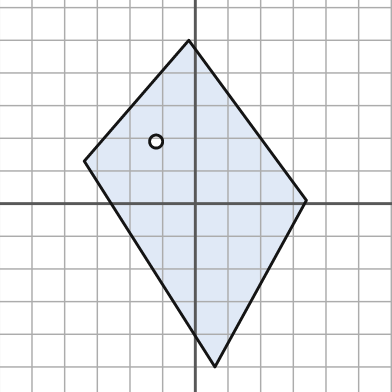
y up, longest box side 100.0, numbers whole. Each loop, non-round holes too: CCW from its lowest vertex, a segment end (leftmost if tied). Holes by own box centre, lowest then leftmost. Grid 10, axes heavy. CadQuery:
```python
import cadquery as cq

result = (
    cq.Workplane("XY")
    .moveTo(6.0, -50.0)
    .lineTo(34.0, 1.0)
    .lineTo(-2.0, 50.0)
    .lineTo(-34.0, 13.0)
    .close()
    .moveTo(-12.0, 19.0)
    .circle(2.0)
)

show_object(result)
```